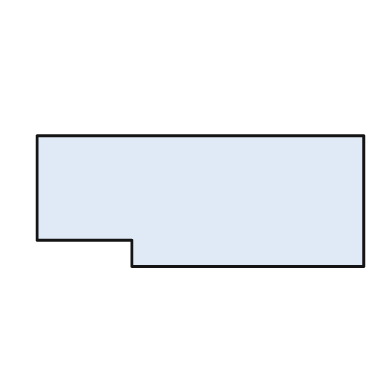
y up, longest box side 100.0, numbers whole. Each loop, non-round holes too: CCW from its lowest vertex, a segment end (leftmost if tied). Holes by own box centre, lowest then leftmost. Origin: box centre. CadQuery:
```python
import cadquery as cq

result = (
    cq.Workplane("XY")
    .moveTo(-21.0, -20.0)
    .lineTo(50.0, -20.0)
    .lineTo(50.0, 20.0)
    .lineTo(-50.0, 20.0)
    .lineTo(-50.0, -12.0)
    .lineTo(-21.0, -12.0)
    .close()
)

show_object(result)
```